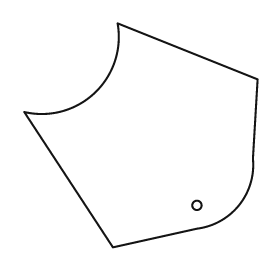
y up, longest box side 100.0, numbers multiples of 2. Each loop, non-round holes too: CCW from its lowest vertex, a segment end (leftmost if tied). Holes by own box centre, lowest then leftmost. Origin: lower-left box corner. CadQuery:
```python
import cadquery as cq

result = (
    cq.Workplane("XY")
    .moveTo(38.0, 0.0)
    .lineTo(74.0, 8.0)
    .threePointArc((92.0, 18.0), (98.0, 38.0))
    .lineTo(100.0, 72.0)
    .lineTo(40.0, 96.0)
    .threePointArc((30.0, 66.0), (0.0, 58.0))
    .close()
    .moveTo(74.0, 18.0)
    .circle(2.0)
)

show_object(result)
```